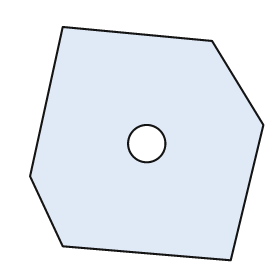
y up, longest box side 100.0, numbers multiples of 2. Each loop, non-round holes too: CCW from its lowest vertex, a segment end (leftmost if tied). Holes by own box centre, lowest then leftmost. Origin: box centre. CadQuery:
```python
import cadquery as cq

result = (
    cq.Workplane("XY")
    .moveTo(36.0, -50.0)
    .lineTo(50.0, 8.0)
    .lineTo(28.0, 44.0)
    .lineTo(-36.0, 50.0)
    .lineTo(-50.0, -14.0)
    .lineTo(-36.0, -44.0)
    .close()
    .moveTo(0.0, 0.0)
    .circle(8.0)
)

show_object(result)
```